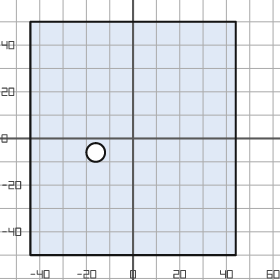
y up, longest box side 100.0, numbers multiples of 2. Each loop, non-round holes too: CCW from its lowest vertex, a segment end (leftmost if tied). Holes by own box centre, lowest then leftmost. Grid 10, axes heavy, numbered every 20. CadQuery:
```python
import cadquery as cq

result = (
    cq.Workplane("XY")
    .moveTo(-44.0, -50.0)
    .lineTo(44.0, -50.0)
    .lineTo(44.0, 50.0)
    .lineTo(-44.0, 50.0)
    .close()
    .moveTo(-16.0, -6.0)
    .circle(4.0)
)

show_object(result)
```